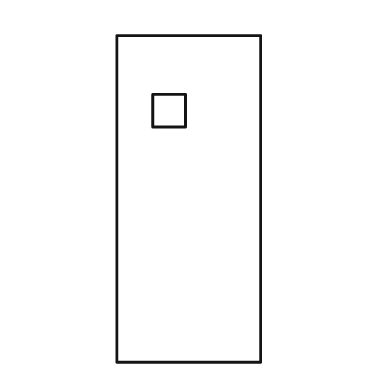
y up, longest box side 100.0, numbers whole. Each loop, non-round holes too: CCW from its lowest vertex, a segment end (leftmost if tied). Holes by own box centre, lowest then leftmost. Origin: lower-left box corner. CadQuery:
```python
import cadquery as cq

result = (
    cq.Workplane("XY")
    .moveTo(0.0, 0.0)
    .lineTo(44.0, 0.0)
    .lineTo(44.0, 100.0)
    .lineTo(0.0, 100.0)
    .close()
    .moveTo(11.0, 72.0)
    .lineTo(21.0, 72.0)
    .lineTo(21.0, 82.0)
    .lineTo(11.0, 82.0)
    .close()
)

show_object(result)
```